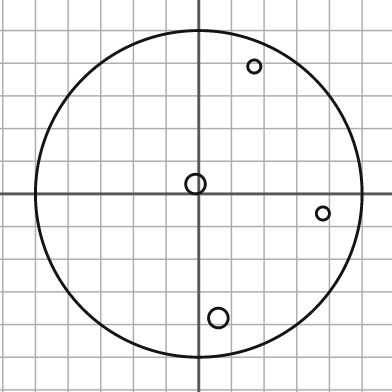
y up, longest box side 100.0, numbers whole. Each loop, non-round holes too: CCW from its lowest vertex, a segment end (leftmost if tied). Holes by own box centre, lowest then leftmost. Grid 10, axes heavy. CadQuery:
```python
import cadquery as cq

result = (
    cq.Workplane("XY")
    .moveTo(0.0, 0.0)
    .circle(50.0)
    .moveTo(6.0, -38.0)
    .circle(3.0)
    .moveTo(38.0, -6.0)
    .circle(2.0)
    .moveTo(-1.0, 3.0)
    .circle(3.0)
    .moveTo(17.0, 39.0)
    .circle(2.0)
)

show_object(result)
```